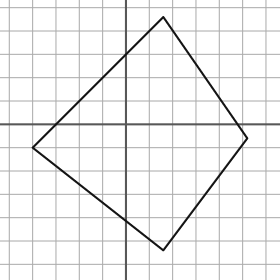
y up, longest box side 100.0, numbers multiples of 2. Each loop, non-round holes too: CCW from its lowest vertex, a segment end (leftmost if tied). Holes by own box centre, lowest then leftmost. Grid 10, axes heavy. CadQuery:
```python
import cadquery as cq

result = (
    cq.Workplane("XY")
    .moveTo(16.0, -54.0)
    .lineTo(52.0, -6.0)
    .lineTo(16.0, 46.0)
    .lineTo(-40.0, -10.0)
    .close()
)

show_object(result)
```